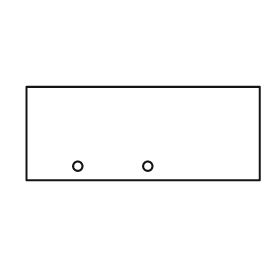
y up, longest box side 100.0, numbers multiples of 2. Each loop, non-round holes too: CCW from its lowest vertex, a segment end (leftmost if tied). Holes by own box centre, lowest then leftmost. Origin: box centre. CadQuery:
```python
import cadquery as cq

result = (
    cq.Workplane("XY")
    .moveTo(-50.0, -20.0)
    .lineTo(50.0, -20.0)
    .lineTo(50.0, 20.0)
    .lineTo(-50.0, 20.0)
    .close()
    .moveTo(-28.0, -14.0)
    .circle(2.0)
    .moveTo(2.0, -14.0)
    .circle(2.0)
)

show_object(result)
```